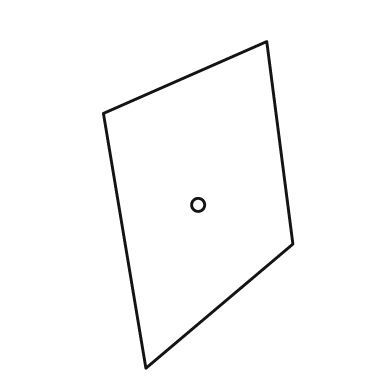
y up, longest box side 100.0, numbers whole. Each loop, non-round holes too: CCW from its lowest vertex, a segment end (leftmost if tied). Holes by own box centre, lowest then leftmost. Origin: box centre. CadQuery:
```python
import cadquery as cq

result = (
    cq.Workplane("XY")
    .moveTo(-16.0, -50.0)
    .lineTo(29.0, -12.0)
    .lineTo(21.0, 50.0)
    .lineTo(-29.0, 28.0)
    .close()
    .moveTo(0.0, 0.0)
    .circle(2.0)
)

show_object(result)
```